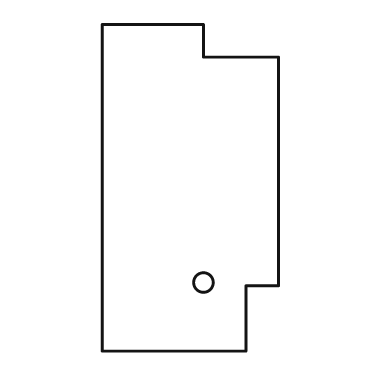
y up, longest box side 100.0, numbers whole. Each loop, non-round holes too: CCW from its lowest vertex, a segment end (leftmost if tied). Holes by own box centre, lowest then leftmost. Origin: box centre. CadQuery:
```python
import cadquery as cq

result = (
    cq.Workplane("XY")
    .moveTo(-27.0, -50.0)
    .lineTo(17.0, -50.0)
    .lineTo(17.0, -30.0)
    .lineTo(27.0, -30.0)
    .lineTo(27.0, 40.0)
    .lineTo(4.0, 40.0)
    .lineTo(4.0, 50.0)
    .lineTo(-27.0, 50.0)
    .close()
    .moveTo(4.0, -29.0)
    .circle(3.0)
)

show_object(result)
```